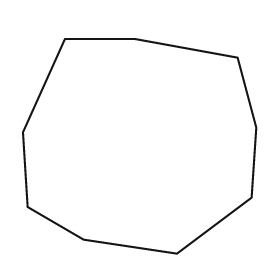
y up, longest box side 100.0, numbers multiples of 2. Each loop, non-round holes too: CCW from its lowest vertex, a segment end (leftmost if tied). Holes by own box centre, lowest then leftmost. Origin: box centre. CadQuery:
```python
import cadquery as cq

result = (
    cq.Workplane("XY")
    .moveTo(16.0, -46.0)
    .lineTo(48.0, -22.0)
    .lineTo(50.0, 8.0)
    .lineTo(42.0, 38.0)
    .lineTo(-2.0, 46.0)
    .lineTo(-32.0, 46.0)
    .lineTo(-50.0, 6.0)
    .lineTo(-48.0, -26.0)
    .lineTo(-24.0, -40.0)
    .close()
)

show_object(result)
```